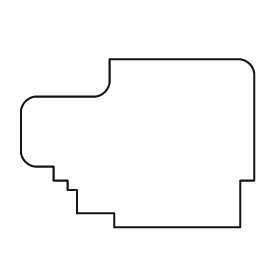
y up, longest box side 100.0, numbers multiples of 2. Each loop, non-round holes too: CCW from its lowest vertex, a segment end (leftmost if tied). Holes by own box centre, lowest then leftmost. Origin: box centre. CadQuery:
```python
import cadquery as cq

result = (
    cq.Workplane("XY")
    .moveTo(-10.0, -36.0)
    .lineTo(44.0, -36.0)
    .lineTo(44.0, -16.0)
    .lineTo(50.0, -16.0)
    .lineTo(50.0, 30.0)
    .threePointArc((48.0, 34.0), (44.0, 36.0))
    .lineTo(-12.0, 36.0)
    .lineTo(-12.0, 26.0)
    .threePointArc((-14.0, 22.0), (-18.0, 20.0))
    .lineTo(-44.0, 20.0)
    .threePointArc((-48.0, 18.0), (-50.0, 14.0))
    .lineTo(-50.0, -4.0)
    .threePointArc((-48.0, -8.0), (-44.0, -10.0))
    .lineTo(-36.0, -10.0)
    .lineTo(-36.0, -16.0)
    .lineTo(-30.0, -16.0)
    .lineTo(-30.0, -20.0)
    .lineTo(-26.0, -20.0)
    .lineTo(-26.0, -30.0)
    .lineTo(-10.0, -30.0)
    .close()
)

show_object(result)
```